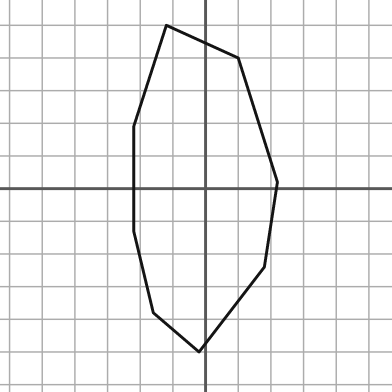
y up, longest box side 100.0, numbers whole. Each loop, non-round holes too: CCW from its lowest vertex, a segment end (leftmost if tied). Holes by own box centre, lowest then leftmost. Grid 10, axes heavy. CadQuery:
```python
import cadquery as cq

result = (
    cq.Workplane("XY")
    .moveTo(-2.0, -50.0)
    .lineTo(18.0, -24.0)
    .lineTo(22.0, 2.0)
    .lineTo(10.0, 40.0)
    .lineTo(-12.0, 50.0)
    .lineTo(-22.0, 19.0)
    .lineTo(-22.0, -13.0)
    .lineTo(-16.0, -38.0)
    .close()
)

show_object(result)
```